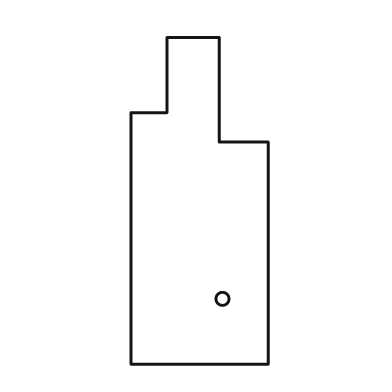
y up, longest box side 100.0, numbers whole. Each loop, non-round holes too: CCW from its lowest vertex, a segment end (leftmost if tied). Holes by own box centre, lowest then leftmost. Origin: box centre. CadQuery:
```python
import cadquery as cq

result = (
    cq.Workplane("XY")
    .moveTo(-21.0, -50.0)
    .lineTo(21.0, -50.0)
    .lineTo(21.0, 18.0)
    .lineTo(6.0, 18.0)
    .lineTo(6.0, 50.0)
    .lineTo(-10.0, 50.0)
    .lineTo(-10.0, 27.0)
    .lineTo(-21.0, 27.0)
    .close()
    .moveTo(7.0, -30.0)
    .circle(2.0)
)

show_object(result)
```